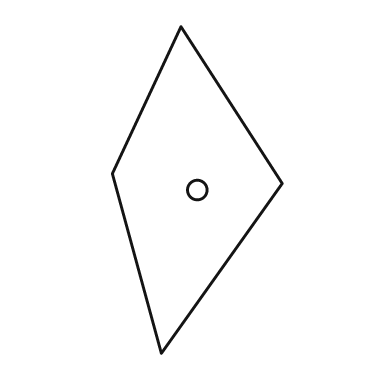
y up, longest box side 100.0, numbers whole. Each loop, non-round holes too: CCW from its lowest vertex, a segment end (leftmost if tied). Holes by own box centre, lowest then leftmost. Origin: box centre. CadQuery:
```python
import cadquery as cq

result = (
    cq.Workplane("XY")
    .moveTo(-11.0, -50.0)
    .lineTo(26.0, 2.0)
    .lineTo(-5.0, 50.0)
    .lineTo(-26.0, 5.0)
    .close()
    .moveTo(0.0, 0.0)
    .circle(3.0)
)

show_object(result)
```